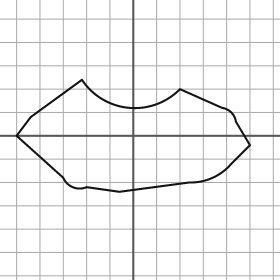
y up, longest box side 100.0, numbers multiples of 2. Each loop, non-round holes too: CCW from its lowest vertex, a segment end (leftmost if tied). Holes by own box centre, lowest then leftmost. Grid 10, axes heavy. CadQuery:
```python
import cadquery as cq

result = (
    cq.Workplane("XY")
    .moveTo(-6.0, -24.0)
    .lineTo(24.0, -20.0)
    .threePointArc((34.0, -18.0), (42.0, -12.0))
    .lineTo(50.0, -4.0)
    .lineTo(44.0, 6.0)
    .threePointArc((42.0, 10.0), (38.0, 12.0))
    .lineTo(20.0, 20.0)
    .threePointArc((-2.0, 12.0), (-22.0, 24.0))
    .lineTo(-44.0, 8.0)
    .lineTo(-50.0, 0.0)
    .lineTo(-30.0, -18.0)
    .threePointArc((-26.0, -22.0), (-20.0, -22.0))
    .close()
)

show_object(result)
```